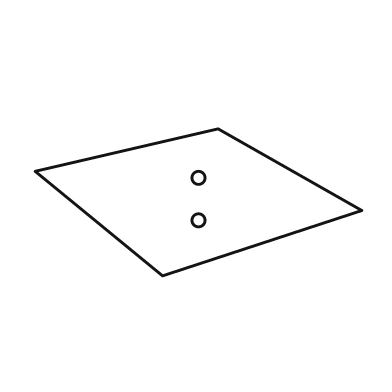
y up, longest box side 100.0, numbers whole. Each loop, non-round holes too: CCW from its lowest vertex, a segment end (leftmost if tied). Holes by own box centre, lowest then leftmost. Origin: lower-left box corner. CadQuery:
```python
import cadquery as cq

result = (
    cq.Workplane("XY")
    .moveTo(39.0, 0.0)
    .lineTo(100.0, 20.0)
    .lineTo(56.0, 45.0)
    .lineTo(0.0, 32.0)
    .close()
    .moveTo(50.0, 17.0)
    .circle(2.0)
    .moveTo(50.0, 30.0)
    .circle(2.0)
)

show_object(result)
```